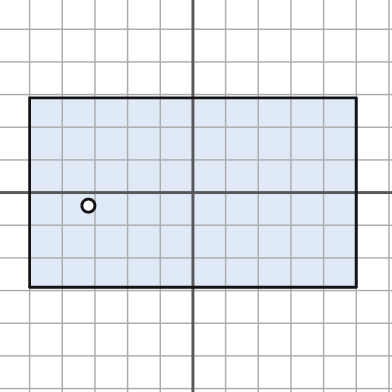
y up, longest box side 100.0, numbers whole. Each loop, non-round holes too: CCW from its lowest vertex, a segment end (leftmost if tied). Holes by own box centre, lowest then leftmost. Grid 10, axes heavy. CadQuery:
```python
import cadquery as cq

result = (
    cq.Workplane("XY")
    .moveTo(-50.0, -29.0)
    .lineTo(50.0, -29.0)
    .lineTo(50.0, 29.0)
    .lineTo(-50.0, 29.0)
    .close()
    .moveTo(-32.0, -4.0)
    .circle(2.0)
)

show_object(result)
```